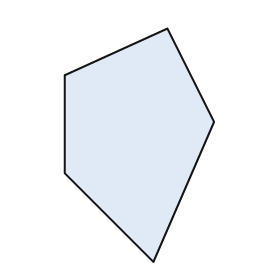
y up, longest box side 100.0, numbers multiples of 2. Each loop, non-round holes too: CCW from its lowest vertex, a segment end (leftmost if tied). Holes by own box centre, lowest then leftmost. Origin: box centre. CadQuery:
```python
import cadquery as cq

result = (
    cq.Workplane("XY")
    .moveTo(6.0, -50.0)
    .lineTo(32.0, 10.0)
    .lineTo(12.0, 50.0)
    .lineTo(-32.0, 30.0)
    .lineTo(-32.0, -12.0)
    .close()
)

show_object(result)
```